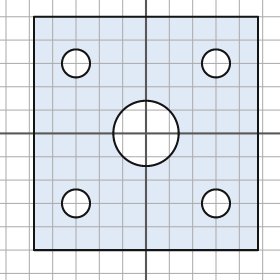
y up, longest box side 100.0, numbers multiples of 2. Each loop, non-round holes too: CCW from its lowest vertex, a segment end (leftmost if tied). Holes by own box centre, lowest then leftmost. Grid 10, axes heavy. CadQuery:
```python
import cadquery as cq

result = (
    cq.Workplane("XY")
    .moveTo(-48.0, -50.0)
    .lineTo(48.0, -50.0)
    .lineTo(48.0, 50.0)
    .lineTo(-48.0, 50.0)
    .close()
    .moveTo(-30.0, -30.0)
    .circle(6.0)
    .moveTo(30.0, -30.0)
    .circle(6.0)
    .moveTo(0.0, 0.0)
    .circle(14.0)
    .moveTo(-30.0, 30.0)
    .circle(6.0)
    .moveTo(30.0, 30.0)
    .circle(6.0)
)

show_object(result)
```